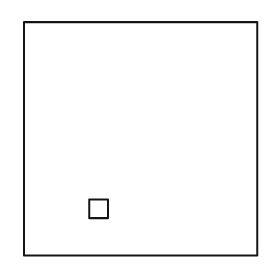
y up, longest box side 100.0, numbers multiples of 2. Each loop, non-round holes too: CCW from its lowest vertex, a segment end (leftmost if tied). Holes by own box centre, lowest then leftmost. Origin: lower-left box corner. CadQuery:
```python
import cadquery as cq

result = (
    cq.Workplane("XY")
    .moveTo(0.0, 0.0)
    .lineTo(100.0, 0.0)
    .lineTo(100.0, 100.0)
    .lineTo(0.0, 100.0)
    .close()
    .moveTo(28.0, 16.0)
    .lineTo(36.0, 16.0)
    .lineTo(36.0, 24.0)
    .lineTo(28.0, 24.0)
    .close()
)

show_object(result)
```